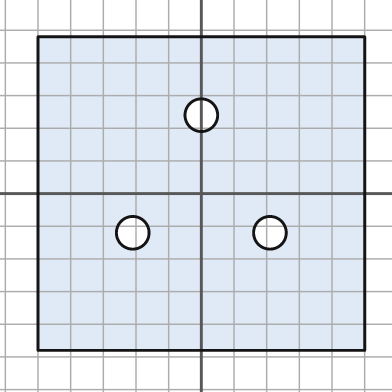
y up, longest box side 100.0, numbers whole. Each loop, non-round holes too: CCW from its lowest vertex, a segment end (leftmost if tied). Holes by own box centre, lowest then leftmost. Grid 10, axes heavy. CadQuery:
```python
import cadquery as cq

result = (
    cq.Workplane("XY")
    .moveTo(-50.0, -48.0)
    .lineTo(50.0, -48.0)
    .lineTo(50.0, 48.0)
    .lineTo(-50.0, 48.0)
    .close()
    .moveTo(-21.0, -12.0)
    .circle(5.0)
    .moveTo(21.0, -12.0)
    .circle(5.0)
    .moveTo(0.0, 24.0)
    .circle(5.0)
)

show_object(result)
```